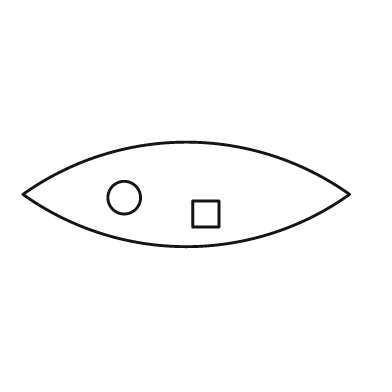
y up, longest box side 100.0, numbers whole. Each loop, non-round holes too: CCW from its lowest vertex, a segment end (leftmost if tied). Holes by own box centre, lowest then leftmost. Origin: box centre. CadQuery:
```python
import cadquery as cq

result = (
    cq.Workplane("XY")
    .moveTo(-50.0, 0.0)
    .threePointArc((0.0, -16.0), (50.0, 0.0))
    .threePointArc((0.0, 16.0), (-50.0, 0.0))
    .close()
    .moveTo(2.0, -10.0)
    .lineTo(10.0, -10.0)
    .lineTo(10.0, -2.0)
    .lineTo(2.0, -2.0)
    .close()
    .moveTo(-19.0, -1.0)
    .circle(5.0)
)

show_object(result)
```